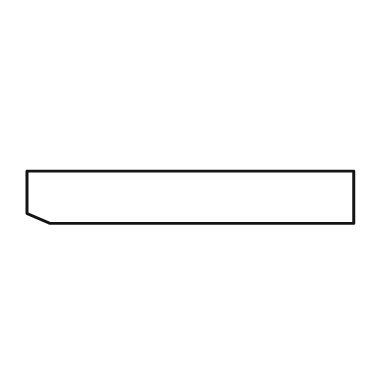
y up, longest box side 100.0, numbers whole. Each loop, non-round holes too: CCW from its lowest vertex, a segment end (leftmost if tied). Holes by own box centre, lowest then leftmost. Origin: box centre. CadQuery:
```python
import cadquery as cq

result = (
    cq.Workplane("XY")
    .moveTo(-43.0, -8.0)
    .lineTo(50.0, -8.0)
    .lineTo(50.0, 8.0)
    .lineTo(-50.0, 8.0)
    .lineTo(-50.0, -5.0)
    .close()
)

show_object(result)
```